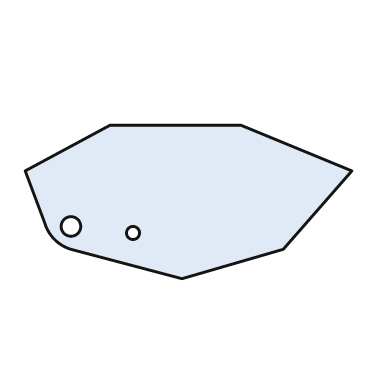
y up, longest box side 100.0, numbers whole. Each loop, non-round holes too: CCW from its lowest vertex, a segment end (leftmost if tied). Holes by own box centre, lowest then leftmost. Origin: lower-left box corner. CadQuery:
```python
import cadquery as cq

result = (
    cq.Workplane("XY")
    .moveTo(48.0, 0.0)
    .lineTo(79.0, 9.0)
    .lineTo(100.0, 33.0)
    .lineTo(66.0, 47.0)
    .lineTo(26.0, 47.0)
    .lineTo(0.0, 33.0)
    .lineTo(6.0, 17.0)
    .threePointArc((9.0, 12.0), (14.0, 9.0))
    .close()
    .moveTo(33.0, 14.0)
    .circle(2.0)
    .moveTo(14.0, 16.0)
    .circle(3.0)
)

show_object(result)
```